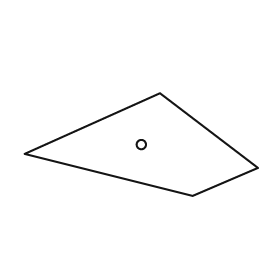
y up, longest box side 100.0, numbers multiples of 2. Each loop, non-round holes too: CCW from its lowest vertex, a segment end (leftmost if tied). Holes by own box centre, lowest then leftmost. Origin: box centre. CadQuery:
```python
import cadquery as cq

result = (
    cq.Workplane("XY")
    .moveTo(22.0, -22.0)
    .lineTo(50.0, -10.0)
    .lineTo(8.0, 22.0)
    .lineTo(-50.0, -4.0)
    .close()
    .moveTo(0.0, 0.0)
    .circle(2.0)
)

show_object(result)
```